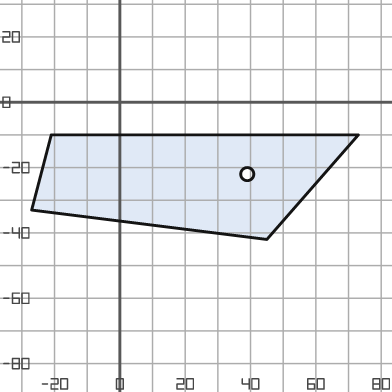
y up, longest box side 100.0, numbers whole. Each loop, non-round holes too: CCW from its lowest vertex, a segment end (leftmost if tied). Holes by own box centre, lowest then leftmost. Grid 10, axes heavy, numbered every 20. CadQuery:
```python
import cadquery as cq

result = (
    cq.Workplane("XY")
    .moveTo(45.0, -42.0)
    .lineTo(73.0, -10.0)
    .lineTo(-21.0, -10.0)
    .lineTo(-27.0, -33.0)
    .close()
    .moveTo(39.0, -22.0)
    .circle(2.0)
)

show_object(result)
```